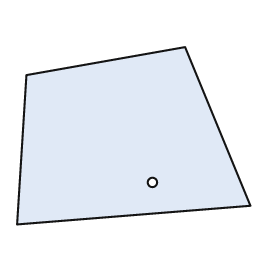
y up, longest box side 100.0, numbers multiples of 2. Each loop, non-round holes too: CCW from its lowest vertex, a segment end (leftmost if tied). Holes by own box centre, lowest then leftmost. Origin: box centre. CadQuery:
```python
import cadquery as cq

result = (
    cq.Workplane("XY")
    .moveTo(-50.0, -38.0)
    .lineTo(50.0, -30.0)
    .lineTo(22.0, 38.0)
    .lineTo(-46.0, 26.0)
    .close()
    .moveTo(8.0, -20.0)
    .circle(2.0)
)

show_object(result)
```